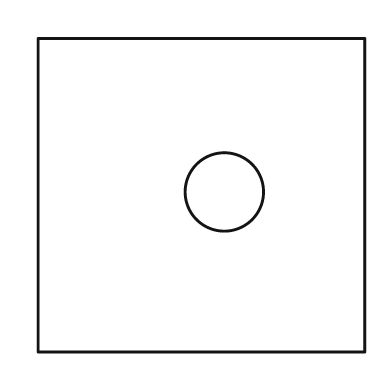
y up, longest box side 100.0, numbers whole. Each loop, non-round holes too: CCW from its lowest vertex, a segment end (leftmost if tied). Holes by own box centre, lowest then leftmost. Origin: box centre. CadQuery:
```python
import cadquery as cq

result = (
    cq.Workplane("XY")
    .moveTo(-50.0, -48.0)
    .lineTo(50.0, -48.0)
    .lineTo(50.0, 48.0)
    .lineTo(-50.0, 48.0)
    .close()
    .moveTo(7.0, 1.0)
    .circle(12.0)
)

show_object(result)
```